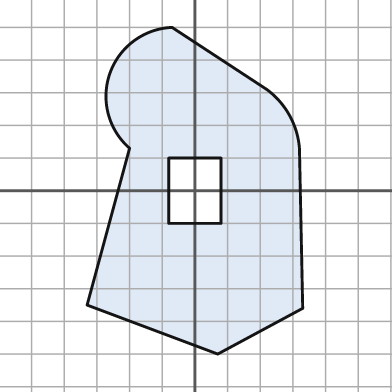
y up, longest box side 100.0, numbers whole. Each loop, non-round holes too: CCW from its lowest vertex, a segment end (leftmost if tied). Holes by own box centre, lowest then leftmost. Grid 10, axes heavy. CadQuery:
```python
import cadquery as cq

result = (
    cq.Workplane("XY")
    .moveTo(7.0, -50.0)
    .lineTo(33.0, -36.0)
    .lineTo(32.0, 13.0)
    .threePointArc((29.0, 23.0), (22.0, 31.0))
    .lineTo(-7.0, 50.0)
    .threePointArc((-26.0, 36.0), (-20.0, 13.0))
    .lineTo(-33.0, -35.0)
    .close()
    .moveTo(-8.0, -10.0)
    .lineTo(8.0, -10.0)
    .lineTo(8.0, 10.0)
    .lineTo(-8.0, 10.0)
    .close()
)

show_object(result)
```